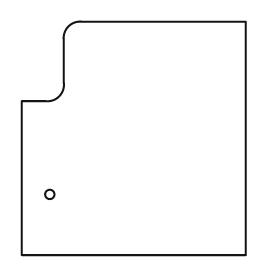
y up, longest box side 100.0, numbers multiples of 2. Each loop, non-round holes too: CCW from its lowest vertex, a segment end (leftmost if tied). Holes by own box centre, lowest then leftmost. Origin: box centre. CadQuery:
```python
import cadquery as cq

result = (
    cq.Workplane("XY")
    .moveTo(-48.0, -50.0)
    .lineTo(48.0, -50.0)
    .lineTo(48.0, 50.0)
    .lineTo(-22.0, 50.0)
    .threePointArc((-28.0, 48.0), (-30.0, 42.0))
    .lineTo(-30.0, 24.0)
    .threePointArc((-32.0, 18.0), (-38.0, 16.0))
    .lineTo(-48.0, 16.0)
    .close()
    .moveTo(-36.0, -24.0)
    .circle(2.0)
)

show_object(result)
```